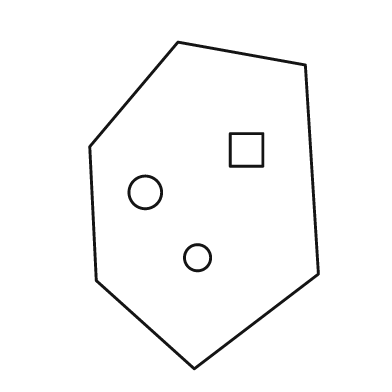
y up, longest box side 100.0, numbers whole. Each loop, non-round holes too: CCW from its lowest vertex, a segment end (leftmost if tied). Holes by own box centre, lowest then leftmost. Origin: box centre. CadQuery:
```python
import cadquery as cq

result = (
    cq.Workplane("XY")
    .moveTo(-3.0, -50.0)
    .lineTo(35.0, -21.0)
    .lineTo(31.0, 43.0)
    .lineTo(-8.0, 50.0)
    .lineTo(-35.0, 18.0)
    .lineTo(-33.0, -23.0)
    .close()
    .moveTo(-2.0, -16.0)
    .circle(4.0)
    .moveTo(-18.0, 4.0)
    .circle(5.0)
    .moveTo(8.0, 12.0)
    .lineTo(18.0, 12.0)
    .lineTo(18.0, 22.0)
    .lineTo(8.0, 22.0)
    .close()
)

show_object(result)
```